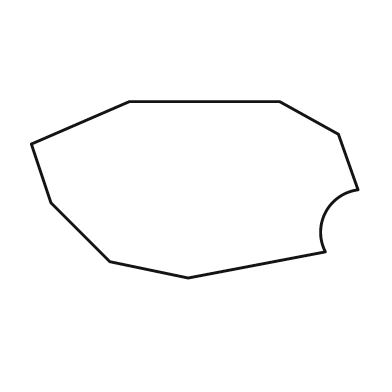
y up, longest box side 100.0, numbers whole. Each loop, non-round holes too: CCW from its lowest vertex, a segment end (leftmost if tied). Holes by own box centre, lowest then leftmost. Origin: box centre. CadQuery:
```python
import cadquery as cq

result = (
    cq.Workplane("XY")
    .moveTo(-2.0, -27.0)
    .lineTo(40.0, -19.0)
    .threePointArc((40.0, -7.0), (50.0, 0.0))
    .lineTo(44.0, 17.0)
    .lineTo(26.0, 27.0)
    .lineTo(-20.0, 27.0)
    .lineTo(-50.0, 14.0)
    .lineTo(-44.0, -4.0)
    .lineTo(-26.0, -22.0)
    .close()
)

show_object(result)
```